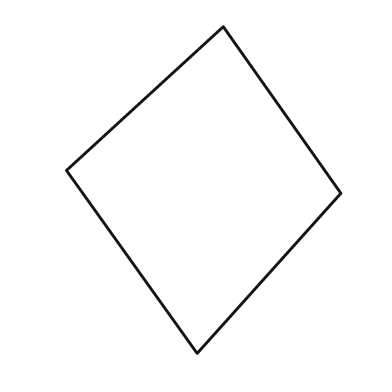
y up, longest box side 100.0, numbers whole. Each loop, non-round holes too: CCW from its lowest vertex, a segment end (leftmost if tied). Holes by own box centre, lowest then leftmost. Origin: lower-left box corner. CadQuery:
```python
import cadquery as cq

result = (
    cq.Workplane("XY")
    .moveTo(40.0, 0.0)
    .lineTo(84.0, 49.0)
    .lineTo(48.0, 100.0)
    .lineTo(0.0, 56.0)
    .close()
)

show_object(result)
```